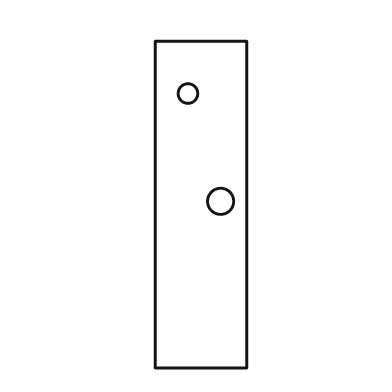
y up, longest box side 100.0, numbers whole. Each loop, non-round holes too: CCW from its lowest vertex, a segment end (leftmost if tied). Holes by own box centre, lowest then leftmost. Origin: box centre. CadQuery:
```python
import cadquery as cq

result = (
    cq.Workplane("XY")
    .moveTo(-14.0, -50.0)
    .lineTo(14.0, -50.0)
    .lineTo(14.0, 50.0)
    .lineTo(-14.0, 50.0)
    .close()
    .moveTo(6.0, 1.0)
    .circle(4.0)
    .moveTo(-4.0, 34.0)
    .circle(3.0)
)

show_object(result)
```